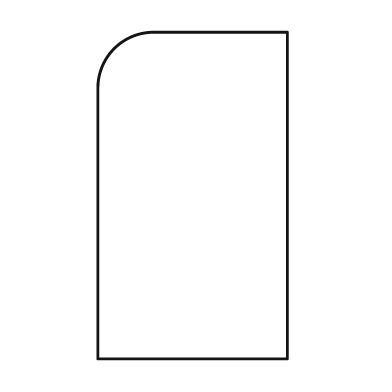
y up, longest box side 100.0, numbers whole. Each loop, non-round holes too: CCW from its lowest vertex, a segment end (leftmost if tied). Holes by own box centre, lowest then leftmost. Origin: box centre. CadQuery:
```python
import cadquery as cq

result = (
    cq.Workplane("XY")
    .moveTo(-29.0, -50.0)
    .lineTo(29.0, -50.0)
    .lineTo(29.0, 50.0)
    .lineTo(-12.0, 50.0)
    .threePointArc((-24.0, 45.0), (-29.0, 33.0))
    .close()
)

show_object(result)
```